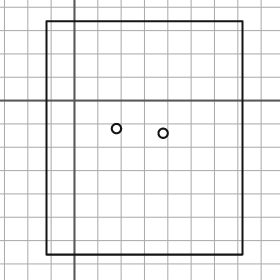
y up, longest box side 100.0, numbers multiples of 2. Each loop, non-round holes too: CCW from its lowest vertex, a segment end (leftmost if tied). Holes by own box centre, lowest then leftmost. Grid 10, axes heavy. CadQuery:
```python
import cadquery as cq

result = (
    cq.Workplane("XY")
    .moveTo(-12.0, -66.0)
    .lineTo(72.0, -66.0)
    .lineTo(72.0, 34.0)
    .lineTo(-12.0, 34.0)
    .close()
    .moveTo(38.0, -14.0)
    .circle(2.0)
    .moveTo(18.0, -12.0)
    .circle(2.0)
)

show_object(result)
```